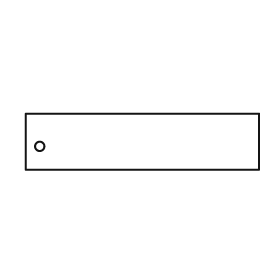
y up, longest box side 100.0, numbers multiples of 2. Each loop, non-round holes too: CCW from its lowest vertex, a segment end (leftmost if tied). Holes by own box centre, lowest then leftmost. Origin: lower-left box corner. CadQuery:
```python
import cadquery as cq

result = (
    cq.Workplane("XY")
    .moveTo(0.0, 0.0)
    .lineTo(100.0, 0.0)
    .lineTo(100.0, 24.0)
    .lineTo(0.0, 24.0)
    .close()
    .moveTo(6.0, 10.0)
    .circle(2.0)
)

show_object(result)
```